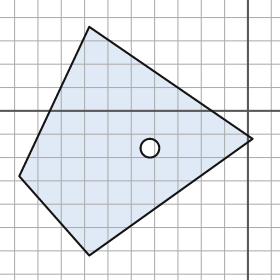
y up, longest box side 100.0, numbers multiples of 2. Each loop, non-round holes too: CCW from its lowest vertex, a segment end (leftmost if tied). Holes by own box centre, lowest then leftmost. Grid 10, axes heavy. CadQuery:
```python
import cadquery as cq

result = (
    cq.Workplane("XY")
    .moveTo(-68.0, -62.0)
    .lineTo(2.0, -12.0)
    .lineTo(-68.0, 36.0)
    .lineTo(-98.0, -28.0)
    .close()
    .moveTo(-42.0, -16.0)
    .circle(4.0)
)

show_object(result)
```